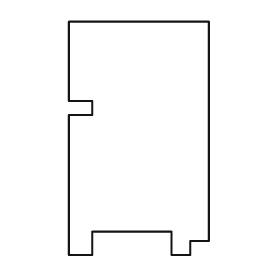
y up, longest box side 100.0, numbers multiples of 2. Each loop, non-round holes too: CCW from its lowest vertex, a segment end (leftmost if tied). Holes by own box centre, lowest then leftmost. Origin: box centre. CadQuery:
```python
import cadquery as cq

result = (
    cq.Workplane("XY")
    .moveTo(-30.0, -50.0)
    .lineTo(-20.0, -50.0)
    .lineTo(-20.0, -40.0)
    .lineTo(14.0, -40.0)
    .lineTo(14.0, -50.0)
    .lineTo(22.0, -50.0)
    .lineTo(22.0, -44.0)
    .lineTo(30.0, -44.0)
    .lineTo(30.0, 50.0)
    .lineTo(-30.0, 50.0)
    .lineTo(-30.0, 16.0)
    .lineTo(-20.0, 16.0)
    .lineTo(-20.0, 10.0)
    .lineTo(-30.0, 10.0)
    .close()
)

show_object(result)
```